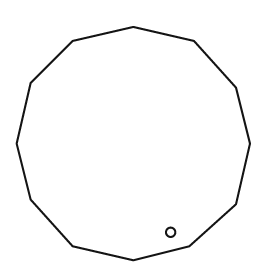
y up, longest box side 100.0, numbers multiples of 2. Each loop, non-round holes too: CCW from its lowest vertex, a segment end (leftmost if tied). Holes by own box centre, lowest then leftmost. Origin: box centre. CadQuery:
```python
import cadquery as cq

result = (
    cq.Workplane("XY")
    .moveTo(0.0, -50.0)
    .lineTo(24.0, -44.0)
    .lineTo(44.0, -26.0)
    .lineTo(50.0, 0.0)
    .lineTo(44.0, 24.0)
    .lineTo(26.0, 44.0)
    .lineTo(0.0, 50.0)
    .lineTo(-26.0, 44.0)
    .lineTo(-44.0, 26.0)
    .lineTo(-50.0, 0.0)
    .lineTo(-44.0, -24.0)
    .lineTo(-26.0, -44.0)
    .close()
    .moveTo(16.0, -38.0)
    .circle(2.0)
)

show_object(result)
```